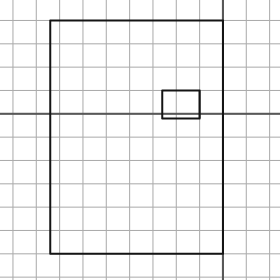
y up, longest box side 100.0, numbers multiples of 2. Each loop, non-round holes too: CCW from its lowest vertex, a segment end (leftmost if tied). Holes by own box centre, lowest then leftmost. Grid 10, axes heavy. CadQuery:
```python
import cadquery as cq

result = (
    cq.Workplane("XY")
    .moveTo(-74.0, -60.0)
    .lineTo(0.0, -60.0)
    .lineTo(0.0, 40.0)
    .lineTo(-74.0, 40.0)
    .close()
    .moveTo(-26.0, -2.0)
    .lineTo(-10.0, -2.0)
    .lineTo(-10.0, 10.0)
    .lineTo(-26.0, 10.0)
    .close()
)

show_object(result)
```